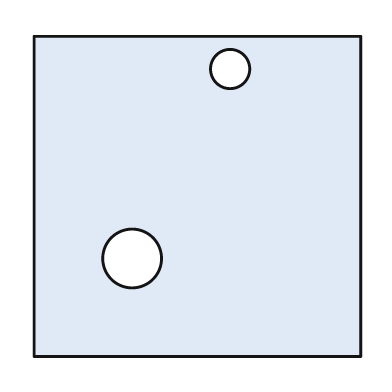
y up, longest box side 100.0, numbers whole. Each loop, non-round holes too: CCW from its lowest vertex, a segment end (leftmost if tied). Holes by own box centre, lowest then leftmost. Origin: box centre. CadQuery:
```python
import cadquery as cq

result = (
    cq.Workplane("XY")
    .moveTo(-50.0, -49.0)
    .lineTo(50.0, -49.0)
    .lineTo(50.0, 49.0)
    .lineTo(-50.0, 49.0)
    .close()
    .moveTo(-20.0, -19.0)
    .circle(9.0)
    .moveTo(10.0, 39.0)
    .circle(6.0)
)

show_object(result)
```